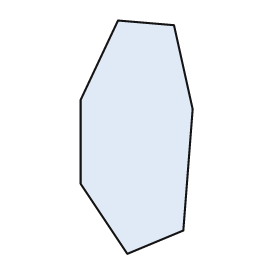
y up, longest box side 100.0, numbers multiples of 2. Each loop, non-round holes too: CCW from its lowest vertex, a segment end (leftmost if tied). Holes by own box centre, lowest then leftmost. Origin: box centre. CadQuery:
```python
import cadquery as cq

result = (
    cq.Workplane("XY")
    .moveTo(-4.0, -50.0)
    .lineTo(20.0, -40.0)
    .lineTo(24.0, 12.0)
    .lineTo(16.0, 48.0)
    .lineTo(-8.0, 50.0)
    .lineTo(-24.0, 16.0)
    .lineTo(-24.0, -20.0)
    .close()
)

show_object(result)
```